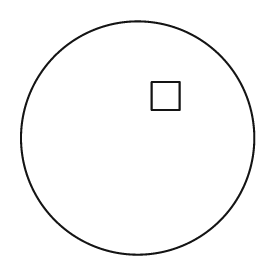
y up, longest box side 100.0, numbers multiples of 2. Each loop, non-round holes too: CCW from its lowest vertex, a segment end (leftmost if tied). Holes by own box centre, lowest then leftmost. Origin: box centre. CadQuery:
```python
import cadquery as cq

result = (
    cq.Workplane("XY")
    .moveTo(0.0, 0.0)
    .circle(50.0)
    .moveTo(6.0, 12.0)
    .lineTo(18.0, 12.0)
    .lineTo(18.0, 24.0)
    .lineTo(6.0, 24.0)
    .close()
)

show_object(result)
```